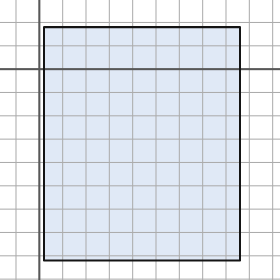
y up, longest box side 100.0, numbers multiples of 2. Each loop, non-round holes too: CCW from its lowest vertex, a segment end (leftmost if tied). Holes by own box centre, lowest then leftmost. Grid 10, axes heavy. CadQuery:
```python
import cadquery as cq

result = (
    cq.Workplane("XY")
    .moveTo(2.0, -82.0)
    .lineTo(86.0, -82.0)
    .lineTo(86.0, 18.0)
    .lineTo(2.0, 18.0)
    .close()
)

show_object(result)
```